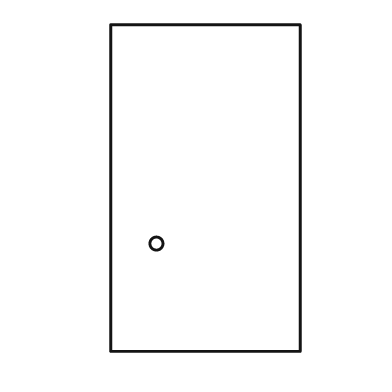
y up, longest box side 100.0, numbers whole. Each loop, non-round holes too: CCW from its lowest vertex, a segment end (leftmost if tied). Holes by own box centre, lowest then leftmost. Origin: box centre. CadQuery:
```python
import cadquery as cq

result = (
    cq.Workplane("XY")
    .moveTo(-29.0, -50.0)
    .lineTo(29.0, -50.0)
    .lineTo(29.0, 50.0)
    .lineTo(-29.0, 50.0)
    .close()
    .moveTo(-15.0, -17.0)
    .circle(2.0)
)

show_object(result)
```